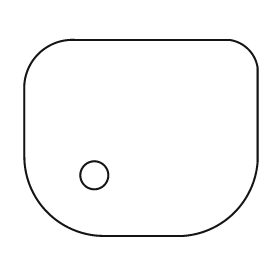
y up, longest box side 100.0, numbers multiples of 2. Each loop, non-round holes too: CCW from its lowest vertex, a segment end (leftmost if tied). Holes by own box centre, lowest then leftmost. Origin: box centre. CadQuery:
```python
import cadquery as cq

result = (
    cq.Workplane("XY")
    .moveTo(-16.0, -42.0)
    .lineTo(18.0, -42.0)
    .threePointArc((40.0, -32.0), (50.0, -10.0))
    .lineTo(50.0, 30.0)
    .threePointArc((46.0, 38.0), (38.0, 42.0))
    .lineTo(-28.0, 42.0)
    .threePointArc((-44.0, 36.0), (-50.0, 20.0))
    .lineTo(-50.0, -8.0)
    .threePointArc((-40.0, -32.0), (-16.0, -42.0))
    .close()
    .moveTo(-20.0, -16.0)
    .circle(6.0)
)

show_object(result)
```